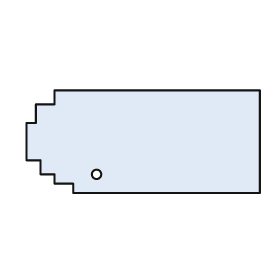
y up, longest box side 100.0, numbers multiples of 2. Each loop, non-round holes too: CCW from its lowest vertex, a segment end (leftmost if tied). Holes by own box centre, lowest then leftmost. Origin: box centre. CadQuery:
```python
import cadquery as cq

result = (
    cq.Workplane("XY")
    .moveTo(-30.0, -22.0)
    .lineTo(50.0, -22.0)
    .lineTo(50.0, 22.0)
    .lineTo(-38.0, 22.0)
    .lineTo(-38.0, 16.0)
    .lineTo(-46.0, 16.0)
    .lineTo(-46.0, 8.0)
    .lineTo(-50.0, 8.0)
    .lineTo(-50.0, -8.0)
    .lineTo(-44.0, -8.0)
    .lineTo(-44.0, -14.0)
    .lineTo(-38.0, -14.0)
    .lineTo(-38.0, -18.0)
    .lineTo(-30.0, -18.0)
    .close()
    .moveTo(-20.0, -14.0)
    .circle(2.0)
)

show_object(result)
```